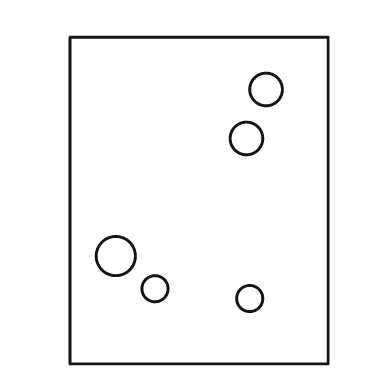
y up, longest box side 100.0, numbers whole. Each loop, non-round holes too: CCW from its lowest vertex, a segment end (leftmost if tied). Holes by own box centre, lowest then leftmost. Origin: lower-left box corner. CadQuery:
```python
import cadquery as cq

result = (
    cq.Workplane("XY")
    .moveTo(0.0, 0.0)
    .lineTo(79.0, 0.0)
    .lineTo(79.0, 100.0)
    .lineTo(0.0, 100.0)
    .close()
    .moveTo(55.0, 20.0)
    .circle(4.0)
    .moveTo(26.0, 23.0)
    .circle(4.0)
    .moveTo(14.0, 33.0)
    .circle(6.0)
    .moveTo(54.0, 69.0)
    .circle(5.0)
    .moveTo(60.0, 84.0)
    .circle(5.0)
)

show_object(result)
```